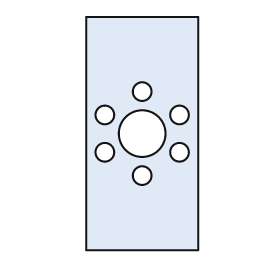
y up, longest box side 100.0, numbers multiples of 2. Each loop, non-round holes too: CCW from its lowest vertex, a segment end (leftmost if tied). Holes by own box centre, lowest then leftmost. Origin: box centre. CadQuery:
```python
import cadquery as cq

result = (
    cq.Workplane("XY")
    .moveTo(-24.0, -50.0)
    .lineTo(24.0, -50.0)
    .lineTo(24.0, 50.0)
    .lineTo(-24.0, 50.0)
    .close()
    .moveTo(0.0, -18.0)
    .circle(4.0)
    .moveTo(-16.0, -8.0)
    .circle(4.0)
    .moveTo(16.0, -8.0)
    .circle(4.0)
    .moveTo(0.0, 0.0)
    .circle(10.0)
    .moveTo(-16.0, 8.0)
    .circle(4.0)
    .moveTo(16.0, 8.0)
    .circle(4.0)
    .moveTo(0.0, 18.0)
    .circle(4.0)
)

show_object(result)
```